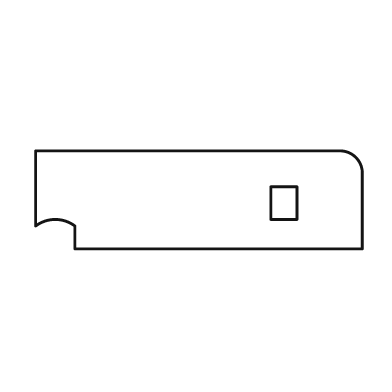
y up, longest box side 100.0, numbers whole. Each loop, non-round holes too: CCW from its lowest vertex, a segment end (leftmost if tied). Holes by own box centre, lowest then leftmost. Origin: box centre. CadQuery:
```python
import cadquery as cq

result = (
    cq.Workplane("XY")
    .moveTo(-38.0, -15.0)
    .lineTo(50.0, -15.0)
    .lineTo(50.0, 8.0)
    .threePointArc((48.0, 13.0), (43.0, 15.0))
    .lineTo(-50.0, 15.0)
    .lineTo(-50.0, -8.0)
    .threePointArc((-44.0, -6.0), (-38.0, -8.0))
    .close()
    .moveTo(22.0, -6.0)
    .lineTo(30.0, -6.0)
    .lineTo(30.0, 4.0)
    .lineTo(22.0, 4.0)
    .close()
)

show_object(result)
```